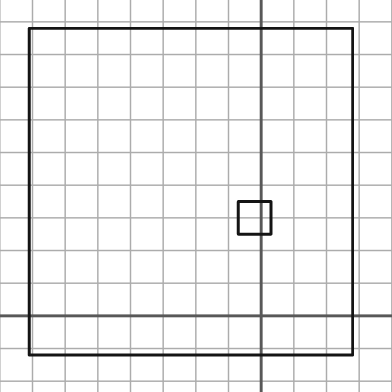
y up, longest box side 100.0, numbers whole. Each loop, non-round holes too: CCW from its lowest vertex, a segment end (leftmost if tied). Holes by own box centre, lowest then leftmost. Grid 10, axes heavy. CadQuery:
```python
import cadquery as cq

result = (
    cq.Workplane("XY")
    .moveTo(-71.0, -12.0)
    .lineTo(28.0, -12.0)
    .lineTo(28.0, 88.0)
    .lineTo(-71.0, 88.0)
    .close()
    .moveTo(-7.0, 25.0)
    .lineTo(3.0, 25.0)
    .lineTo(3.0, 35.0)
    .lineTo(-7.0, 35.0)
    .close()
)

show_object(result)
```